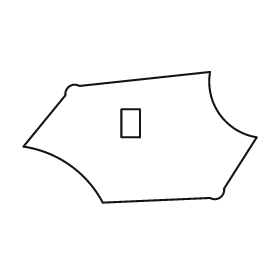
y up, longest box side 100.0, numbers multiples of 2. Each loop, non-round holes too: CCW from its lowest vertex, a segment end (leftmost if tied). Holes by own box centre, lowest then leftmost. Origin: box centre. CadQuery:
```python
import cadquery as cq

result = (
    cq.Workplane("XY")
    .moveTo(-16.0, -28.0)
    .lineTo(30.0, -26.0)
    .threePointArc((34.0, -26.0), (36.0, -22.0))
    .lineTo(50.0, 0.0)
    .threePointArc((34.0, 10.0), (30.0, 28.0))
    .lineTo(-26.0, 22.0)
    .threePointArc((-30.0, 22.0), (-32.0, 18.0))
    .lineTo(-50.0, -4.0)
    .threePointArc((-30.0, -12.0), (-16.0, -28.0))
    .close()
    .moveTo(-8.0, 0.0)
    .lineTo(0.0, 0.0)
    .lineTo(0.0, 12.0)
    .lineTo(-8.0, 12.0)
    .close()
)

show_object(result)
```